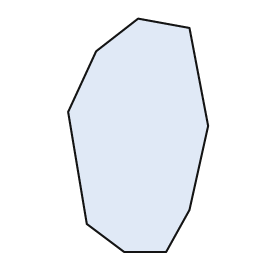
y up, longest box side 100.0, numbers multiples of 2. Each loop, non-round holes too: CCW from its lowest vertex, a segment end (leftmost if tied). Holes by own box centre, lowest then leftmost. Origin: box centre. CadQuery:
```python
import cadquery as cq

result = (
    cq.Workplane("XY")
    .moveTo(-6.0, -50.0)
    .lineTo(12.0, -50.0)
    .lineTo(22.0, -32.0)
    .lineTo(30.0, 4.0)
    .lineTo(22.0, 46.0)
    .lineTo(0.0, 50.0)
    .lineTo(-18.0, 36.0)
    .lineTo(-30.0, 10.0)
    .lineTo(-22.0, -38.0)
    .close()
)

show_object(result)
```